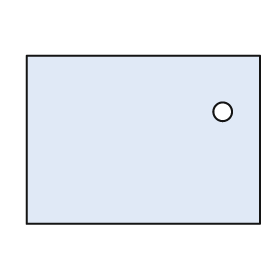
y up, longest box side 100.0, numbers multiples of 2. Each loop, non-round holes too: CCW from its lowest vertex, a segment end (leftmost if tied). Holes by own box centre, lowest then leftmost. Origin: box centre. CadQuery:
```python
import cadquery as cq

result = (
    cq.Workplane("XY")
    .moveTo(-50.0, -36.0)
    .lineTo(50.0, -36.0)
    .lineTo(50.0, 36.0)
    .lineTo(-50.0, 36.0)
    .close()
    .moveTo(34.0, 12.0)
    .circle(4.0)
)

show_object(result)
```